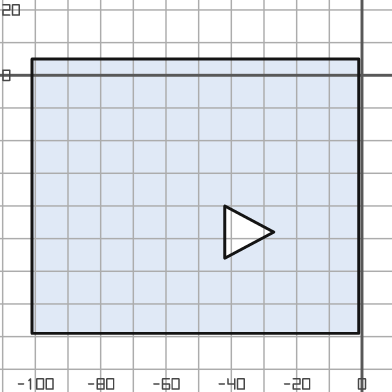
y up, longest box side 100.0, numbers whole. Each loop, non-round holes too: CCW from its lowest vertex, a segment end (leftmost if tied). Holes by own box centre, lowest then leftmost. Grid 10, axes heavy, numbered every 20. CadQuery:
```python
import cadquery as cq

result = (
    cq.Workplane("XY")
    .moveTo(-101.0, -79.0)
    .lineTo(-1.0, -79.0)
    .lineTo(-1.0, 5.0)
    .lineTo(-101.0, 5.0)
    .close()
    .moveTo(-42.0, -56.0)
    .lineTo(-27.0, -48.0)
    .lineTo(-42.0, -40.0)
    .close()
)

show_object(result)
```